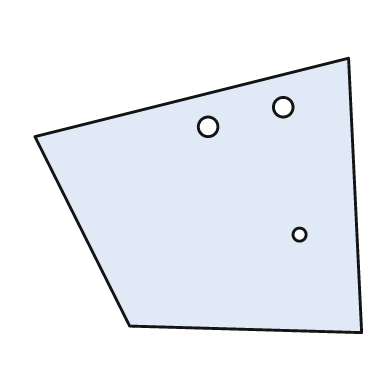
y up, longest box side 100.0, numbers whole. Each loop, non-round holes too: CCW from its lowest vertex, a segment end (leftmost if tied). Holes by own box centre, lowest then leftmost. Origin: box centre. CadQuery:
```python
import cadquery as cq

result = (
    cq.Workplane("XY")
    .moveTo(50.0, -42.0)
    .lineTo(46.0, 42.0)
    .lineTo(-50.0, 18.0)
    .lineTo(-21.0, -40.0)
    .close()
    .moveTo(31.0, -12.0)
    .circle(2.0)
    .moveTo(3.0, 21.0)
    .circle(3.0)
    .moveTo(26.0, 27.0)
    .circle(3.0)
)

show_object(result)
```